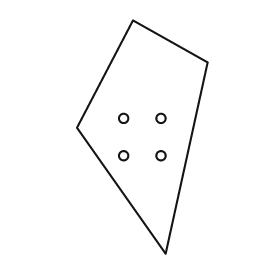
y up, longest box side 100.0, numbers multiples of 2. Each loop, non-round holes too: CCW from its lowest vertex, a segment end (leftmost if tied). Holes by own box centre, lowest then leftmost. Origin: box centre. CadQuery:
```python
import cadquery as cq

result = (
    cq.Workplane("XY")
    .moveTo(10.0, -50.0)
    .lineTo(28.0, 32.0)
    .lineTo(-4.0, 50.0)
    .lineTo(-28.0, 4.0)
    .close()
    .moveTo(-8.0, -8.0)
    .circle(2.0)
    .moveTo(8.0, -8.0)
    .circle(2.0)
    .moveTo(-8.0, 8.0)
    .circle(2.0)
    .moveTo(8.0, 8.0)
    .circle(2.0)
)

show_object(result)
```